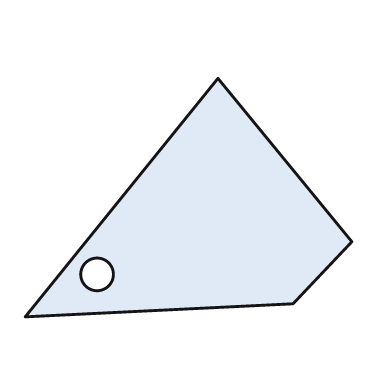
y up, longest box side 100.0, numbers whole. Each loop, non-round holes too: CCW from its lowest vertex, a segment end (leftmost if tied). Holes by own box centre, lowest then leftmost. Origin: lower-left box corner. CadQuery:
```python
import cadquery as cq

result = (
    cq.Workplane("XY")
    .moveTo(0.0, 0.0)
    .lineTo(82.0, 4.0)
    .lineTo(100.0, 23.0)
    .lineTo(59.0, 73.0)
    .close()
    .moveTo(22.0, 13.0)
    .circle(5.0)
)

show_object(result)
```